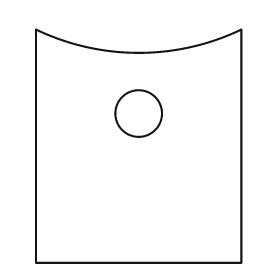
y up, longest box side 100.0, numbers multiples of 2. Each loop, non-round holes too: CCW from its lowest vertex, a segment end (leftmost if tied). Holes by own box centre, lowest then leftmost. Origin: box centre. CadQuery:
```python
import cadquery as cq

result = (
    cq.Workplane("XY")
    .moveTo(-44.0, -50.0)
    .lineTo(44.0, -50.0)
    .lineTo(44.0, 50.0)
    .threePointArc((0.0, 40.0), (-44.0, 50.0))
    .close()
    .moveTo(0.0, 14.0)
    .circle(10.0)
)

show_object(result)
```